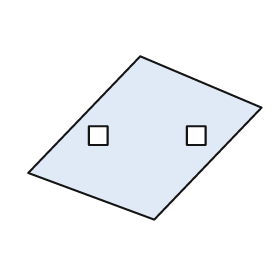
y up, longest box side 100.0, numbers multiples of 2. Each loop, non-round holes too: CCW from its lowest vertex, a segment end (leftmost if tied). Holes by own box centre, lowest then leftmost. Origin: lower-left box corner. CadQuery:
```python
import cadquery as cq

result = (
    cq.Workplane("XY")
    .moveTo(54.0, 0.0)
    .lineTo(100.0, 48.0)
    .lineTo(48.0, 70.0)
    .lineTo(0.0, 20.0)
    .close()
    .moveTo(26.0, 32.0)
    .lineTo(34.0, 32.0)
    .lineTo(34.0, 40.0)
    .lineTo(26.0, 40.0)
    .close()
    .moveTo(68.0, 32.0)
    .lineTo(76.0, 32.0)
    .lineTo(76.0, 40.0)
    .lineTo(68.0, 40.0)
    .close()
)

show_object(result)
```